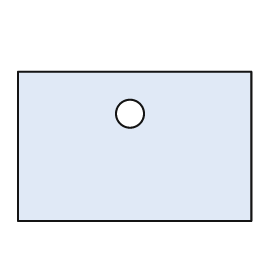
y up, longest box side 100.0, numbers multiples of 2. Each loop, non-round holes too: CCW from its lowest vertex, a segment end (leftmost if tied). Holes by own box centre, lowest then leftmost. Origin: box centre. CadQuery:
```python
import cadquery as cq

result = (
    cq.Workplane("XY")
    .moveTo(-50.0, -32.0)
    .lineTo(50.0, -32.0)
    .lineTo(50.0, 32.0)
    .lineTo(-50.0, 32.0)
    .close()
    .moveTo(-2.0, 14.0)
    .circle(6.0)
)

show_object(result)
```